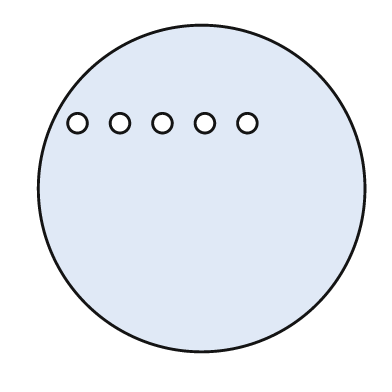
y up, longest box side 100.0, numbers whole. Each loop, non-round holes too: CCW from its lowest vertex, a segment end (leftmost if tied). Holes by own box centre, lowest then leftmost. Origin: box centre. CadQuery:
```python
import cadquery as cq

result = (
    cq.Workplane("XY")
    .moveTo(0.0, 0.0)
    .circle(50.0)
    .moveTo(-38.0, 20.0)
    .circle(3.0)
    .moveTo(-25.0, 20.0)
    .circle(3.0)
    .moveTo(-12.0, 20.0)
    .circle(3.0)
    .moveTo(1.0, 20.0)
    .circle(3.0)
    .moveTo(14.0, 20.0)
    .circle(3.0)
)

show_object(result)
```